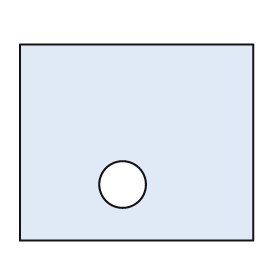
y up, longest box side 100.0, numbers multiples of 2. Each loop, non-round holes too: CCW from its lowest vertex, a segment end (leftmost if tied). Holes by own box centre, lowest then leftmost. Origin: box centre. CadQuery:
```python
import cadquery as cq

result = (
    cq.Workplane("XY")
    .moveTo(-50.0, -42.0)
    .lineTo(50.0, -42.0)
    .lineTo(50.0, 42.0)
    .lineTo(-50.0, 42.0)
    .close()
    .moveTo(-6.0, -18.0)
    .circle(10.0)
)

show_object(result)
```